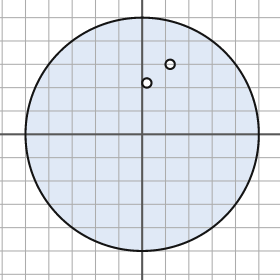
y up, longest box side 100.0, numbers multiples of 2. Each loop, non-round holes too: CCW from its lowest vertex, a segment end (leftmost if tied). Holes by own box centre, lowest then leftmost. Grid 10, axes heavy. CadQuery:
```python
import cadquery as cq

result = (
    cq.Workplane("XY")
    .moveTo(0.0, 0.0)
    .circle(50.0)
    .moveTo(2.0, 22.0)
    .circle(2.0)
    .moveTo(12.0, 30.0)
    .circle(2.0)
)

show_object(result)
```